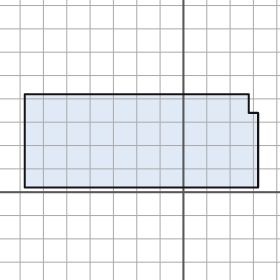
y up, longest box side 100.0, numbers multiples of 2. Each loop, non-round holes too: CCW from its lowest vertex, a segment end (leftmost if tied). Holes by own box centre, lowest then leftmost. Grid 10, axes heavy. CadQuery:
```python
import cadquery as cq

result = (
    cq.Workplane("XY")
    .moveTo(-68.0, 2.0)
    .lineTo(32.0, 2.0)
    .lineTo(32.0, 34.0)
    .lineTo(28.0, 34.0)
    .lineTo(28.0, 42.0)
    .lineTo(-68.0, 42.0)
    .close()
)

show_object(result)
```